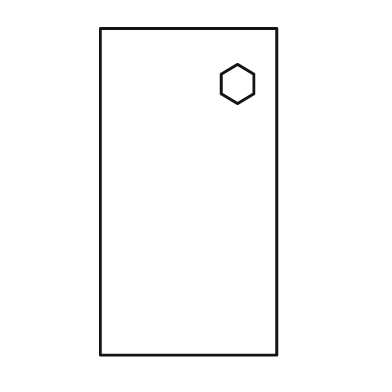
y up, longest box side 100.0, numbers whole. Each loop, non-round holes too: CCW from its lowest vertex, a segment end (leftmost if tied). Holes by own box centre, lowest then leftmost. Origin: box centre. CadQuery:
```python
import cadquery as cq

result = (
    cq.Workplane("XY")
    .moveTo(-27.0, -50.0)
    .lineTo(27.0, -50.0)
    .lineTo(27.0, 50.0)
    .lineTo(-27.0, 50.0)
    .close()
    .moveTo(15.0, 27.0)
    .lineTo(20.0, 30.0)
    .lineTo(20.0, 36.0)
    .lineTo(15.0, 39.0)
    .lineTo(10.0, 36.0)
    .lineTo(10.0, 30.0)
    .close()
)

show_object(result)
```